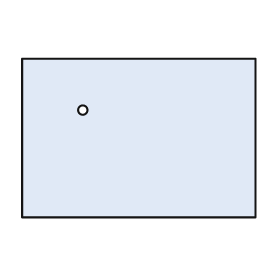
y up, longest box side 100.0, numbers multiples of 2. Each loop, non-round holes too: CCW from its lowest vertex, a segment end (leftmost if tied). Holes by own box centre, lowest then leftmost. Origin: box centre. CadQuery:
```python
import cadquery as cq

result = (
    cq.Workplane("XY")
    .moveTo(-50.0, -34.0)
    .lineTo(50.0, -34.0)
    .lineTo(50.0, 34.0)
    .lineTo(-50.0, 34.0)
    .close()
    .moveTo(-24.0, 12.0)
    .circle(2.0)
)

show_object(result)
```